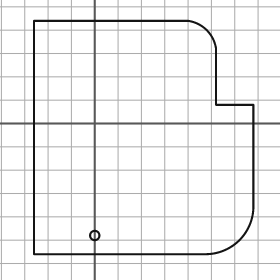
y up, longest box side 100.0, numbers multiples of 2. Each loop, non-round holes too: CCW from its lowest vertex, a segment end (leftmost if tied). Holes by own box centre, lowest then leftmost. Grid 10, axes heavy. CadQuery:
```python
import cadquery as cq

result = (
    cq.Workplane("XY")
    .moveTo(-26.0, -56.0)
    .lineTo(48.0, -56.0)
    .threePointArc((62.0, -50.0), (68.0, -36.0))
    .lineTo(68.0, 8.0)
    .lineTo(52.0, 8.0)
    .lineTo(52.0, 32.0)
    .threePointArc((48.0, 40.0), (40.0, 44.0))
    .lineTo(-26.0, 44.0)
    .close()
    .moveTo(0.0, -48.0)
    .circle(2.0)
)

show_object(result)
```